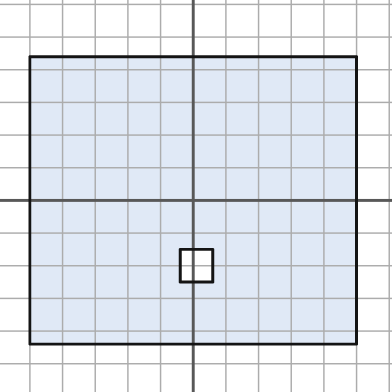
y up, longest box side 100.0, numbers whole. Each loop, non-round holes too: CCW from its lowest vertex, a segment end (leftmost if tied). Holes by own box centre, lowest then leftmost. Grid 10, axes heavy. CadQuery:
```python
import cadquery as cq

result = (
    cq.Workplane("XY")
    .moveTo(-50.0, -44.0)
    .lineTo(50.0, -44.0)
    .lineTo(50.0, 44.0)
    .lineTo(-50.0, 44.0)
    .close()
    .moveTo(-4.0, -25.0)
    .lineTo(6.0, -25.0)
    .lineTo(6.0, -15.0)
    .lineTo(-4.0, -15.0)
    .close()
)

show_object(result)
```